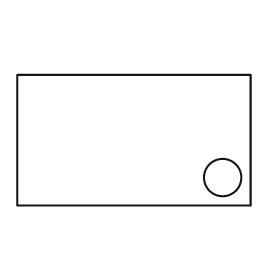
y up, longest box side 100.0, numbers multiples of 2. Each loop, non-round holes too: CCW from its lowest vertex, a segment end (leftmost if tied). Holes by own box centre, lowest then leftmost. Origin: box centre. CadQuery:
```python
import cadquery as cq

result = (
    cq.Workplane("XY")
    .moveTo(-50.0, -28.0)
    .lineTo(50.0, -28.0)
    .lineTo(50.0, 28.0)
    .lineTo(-50.0, 28.0)
    .close()
    .moveTo(38.0, -16.0)
    .circle(8.0)
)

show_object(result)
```